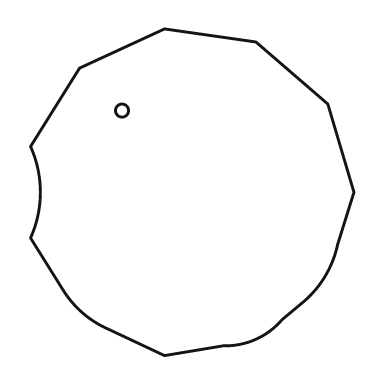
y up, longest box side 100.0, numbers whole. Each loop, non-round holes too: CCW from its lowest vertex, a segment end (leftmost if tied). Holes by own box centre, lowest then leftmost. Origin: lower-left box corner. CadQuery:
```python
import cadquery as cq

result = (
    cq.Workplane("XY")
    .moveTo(41.0, 0.0)
    .lineTo(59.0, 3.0)
    .threePointArc((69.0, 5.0), (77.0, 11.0))
    .lineTo(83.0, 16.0)
    .threePointArc((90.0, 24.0), (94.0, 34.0))
    .lineTo(99.0, 50.0)
    .lineTo(91.0, 77.0)
    .lineTo(69.0, 96.0)
    .lineTo(41.0, 100.0)
    .lineTo(15.0, 88.0)
    .lineTo(0.0, 64.0)
    .threePointArc((3.0, 50.0), (0.0, 36.0))
    .lineTo(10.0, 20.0)
    .threePointArc((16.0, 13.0), (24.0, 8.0))
    .close()
    .moveTo(28.0, 75.0)
    .circle(2.0)
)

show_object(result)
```